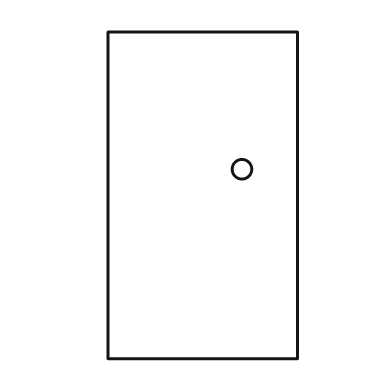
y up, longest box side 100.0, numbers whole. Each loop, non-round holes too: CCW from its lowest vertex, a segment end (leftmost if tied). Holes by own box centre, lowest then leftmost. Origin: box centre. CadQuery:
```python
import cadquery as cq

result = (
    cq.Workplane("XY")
    .moveTo(-29.0, -50.0)
    .lineTo(29.0, -50.0)
    .lineTo(29.0, 50.0)
    .lineTo(-29.0, 50.0)
    .close()
    .moveTo(12.0, 8.0)
    .circle(3.0)
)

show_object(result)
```